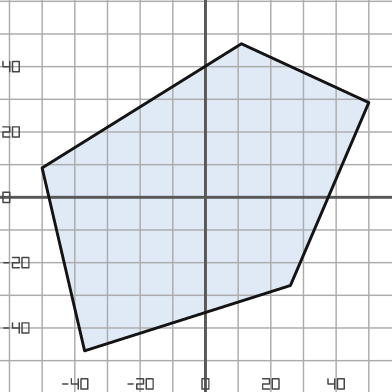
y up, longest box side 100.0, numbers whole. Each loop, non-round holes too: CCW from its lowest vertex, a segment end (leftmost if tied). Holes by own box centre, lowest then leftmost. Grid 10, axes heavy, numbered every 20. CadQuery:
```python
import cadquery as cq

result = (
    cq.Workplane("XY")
    .moveTo(-37.0, -47.0)
    .lineTo(26.0, -27.0)
    .lineTo(50.0, 29.0)
    .lineTo(11.0, 47.0)
    .lineTo(-50.0, 9.0)
    .close()
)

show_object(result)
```